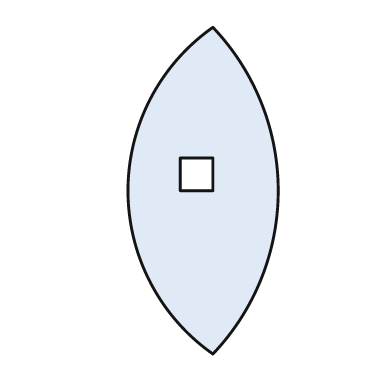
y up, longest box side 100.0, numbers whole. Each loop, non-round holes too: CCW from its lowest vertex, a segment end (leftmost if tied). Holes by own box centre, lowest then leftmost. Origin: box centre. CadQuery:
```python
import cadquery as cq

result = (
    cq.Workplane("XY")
    .moveTo(3.0, -50.0)
    .threePointArc((23.0, 0.0), (3.0, 50.0))
    .threePointArc((-23.0, 0.0), (3.0, -50.0))
    .close()
    .moveTo(-7.0, 0.0)
    .lineTo(3.0, 0.0)
    .lineTo(3.0, 10.0)
    .lineTo(-7.0, 10.0)
    .close()
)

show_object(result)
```